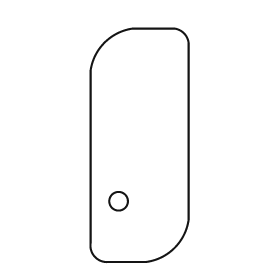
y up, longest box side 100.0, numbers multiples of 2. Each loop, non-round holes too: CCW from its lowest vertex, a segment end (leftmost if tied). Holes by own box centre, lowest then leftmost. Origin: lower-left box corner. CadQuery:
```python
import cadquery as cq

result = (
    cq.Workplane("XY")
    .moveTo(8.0, 0.0)
    .lineTo(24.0, 0.0)
    .threePointArc((36.0, 6.0), (42.0, 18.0))
    .lineTo(42.0, 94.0)
    .threePointArc((40.0, 98.0), (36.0, 100.0))
    .lineTo(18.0, 100.0)
    .threePointArc((6.0, 94.0), (0.0, 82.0))
    .lineTo(0.0, 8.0)
    .threePointArc((2.0, 2.0), (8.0, 0.0))
    .close()
    .moveTo(12.0, 26.0)
    .circle(4.0)
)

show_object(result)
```